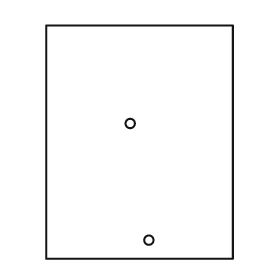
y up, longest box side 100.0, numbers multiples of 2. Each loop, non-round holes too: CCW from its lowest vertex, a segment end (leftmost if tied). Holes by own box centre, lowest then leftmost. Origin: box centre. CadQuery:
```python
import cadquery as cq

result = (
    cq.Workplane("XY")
    .moveTo(-40.0, -50.0)
    .lineTo(40.0, -50.0)
    .lineTo(40.0, 50.0)
    .lineTo(-40.0, 50.0)
    .close()
    .moveTo(4.0, -42.0)
    .circle(2.0)
    .moveTo(-4.0, 8.0)
    .circle(2.0)
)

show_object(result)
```